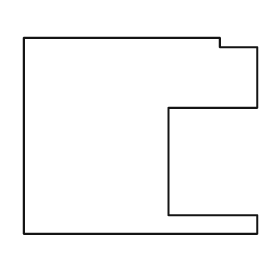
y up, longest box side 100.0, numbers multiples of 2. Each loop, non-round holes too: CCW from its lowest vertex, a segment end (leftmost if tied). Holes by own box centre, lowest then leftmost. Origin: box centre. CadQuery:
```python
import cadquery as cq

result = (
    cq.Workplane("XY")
    .moveTo(-50.0, -42.0)
    .lineTo(50.0, -42.0)
    .lineTo(50.0, -34.0)
    .lineTo(12.0, -34.0)
    .lineTo(12.0, 12.0)
    .lineTo(50.0, 12.0)
    .lineTo(50.0, 38.0)
    .lineTo(34.0, 38.0)
    .lineTo(34.0, 42.0)
    .lineTo(-50.0, 42.0)
    .close()
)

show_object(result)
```